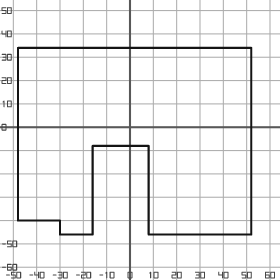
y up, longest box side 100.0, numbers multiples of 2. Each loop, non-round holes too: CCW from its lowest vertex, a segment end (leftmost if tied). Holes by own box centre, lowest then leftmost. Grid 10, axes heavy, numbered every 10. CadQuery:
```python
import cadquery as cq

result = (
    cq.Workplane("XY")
    .moveTo(-30.0, -46.0)
    .lineTo(-16.0, -46.0)
    .lineTo(-16.0, -8.0)
    .lineTo(8.0, -8.0)
    .lineTo(8.0, -46.0)
    .lineTo(52.0, -46.0)
    .lineTo(52.0, 34.0)
    .lineTo(-48.0, 34.0)
    .lineTo(-48.0, -40.0)
    .lineTo(-30.0, -40.0)
    .close()
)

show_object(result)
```